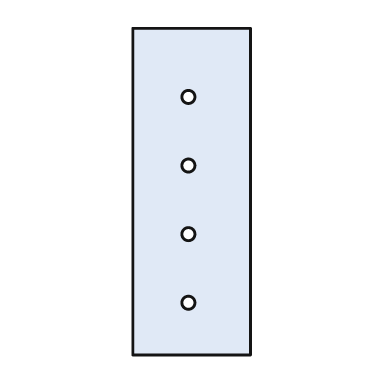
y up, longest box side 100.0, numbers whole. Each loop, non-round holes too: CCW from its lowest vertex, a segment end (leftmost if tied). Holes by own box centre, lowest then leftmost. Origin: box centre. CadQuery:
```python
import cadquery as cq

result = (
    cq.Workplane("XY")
    .moveTo(-18.0, -50.0)
    .lineTo(18.0, -50.0)
    .lineTo(18.0, 50.0)
    .lineTo(-18.0, 50.0)
    .close()
    .moveTo(-1.0, -34.0)
    .circle(2.0)
    .moveTo(-1.0, -13.0)
    .circle(2.0)
    .moveTo(-1.0, 8.0)
    .circle(2.0)
    .moveTo(-1.0, 29.0)
    .circle(2.0)
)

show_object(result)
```